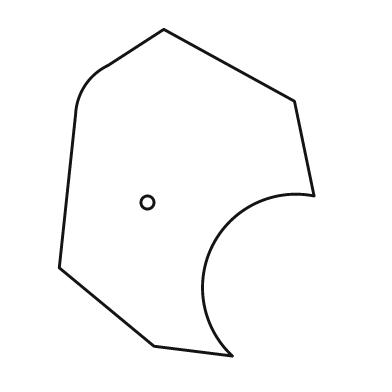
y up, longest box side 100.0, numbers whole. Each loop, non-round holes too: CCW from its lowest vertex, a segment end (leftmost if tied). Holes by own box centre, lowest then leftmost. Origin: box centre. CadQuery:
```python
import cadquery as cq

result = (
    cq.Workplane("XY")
    .moveTo(14.0, -50.0)
    .threePointArc((8.0, -16.0), (39.0, -1.0))
    .lineTo(33.0, 28.0)
    .lineTo(-7.0, 50.0)
    .lineTo(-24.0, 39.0)
    .threePointArc((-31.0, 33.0), (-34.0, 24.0))
    .lineTo(-39.0, -23.0)
    .lineTo(-10.0, -47.0)
    .close()
    .moveTo(-12.0, -3.0)
    .circle(2.0)
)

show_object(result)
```